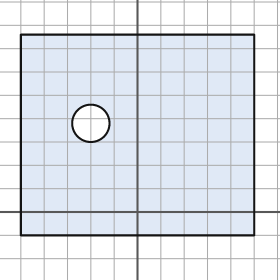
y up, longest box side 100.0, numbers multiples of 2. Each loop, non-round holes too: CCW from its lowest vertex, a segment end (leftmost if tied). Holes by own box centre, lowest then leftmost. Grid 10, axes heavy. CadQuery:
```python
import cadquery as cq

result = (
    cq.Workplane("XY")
    .moveTo(-50.0, -10.0)
    .lineTo(50.0, -10.0)
    .lineTo(50.0, 76.0)
    .lineTo(-50.0, 76.0)
    .close()
    .moveTo(-20.0, 38.0)
    .circle(8.0)
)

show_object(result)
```